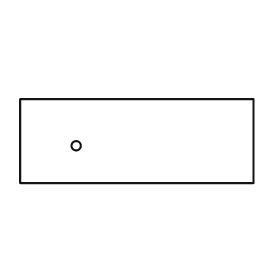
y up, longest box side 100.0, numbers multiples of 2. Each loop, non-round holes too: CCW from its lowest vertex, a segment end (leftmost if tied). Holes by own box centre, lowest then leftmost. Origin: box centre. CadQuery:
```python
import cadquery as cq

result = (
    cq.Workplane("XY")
    .moveTo(-50.0, -18.0)
    .lineTo(50.0, -18.0)
    .lineTo(50.0, 18.0)
    .lineTo(-50.0, 18.0)
    .close()
    .moveTo(-26.0, -2.0)
    .circle(2.0)
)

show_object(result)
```